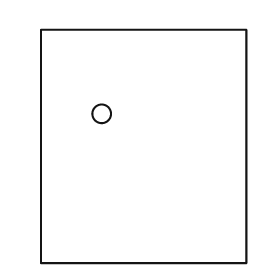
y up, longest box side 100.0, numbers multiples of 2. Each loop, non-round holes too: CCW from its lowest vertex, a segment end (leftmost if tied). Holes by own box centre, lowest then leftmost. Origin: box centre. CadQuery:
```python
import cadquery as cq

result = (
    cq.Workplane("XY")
    .moveTo(-44.0, -50.0)
    .lineTo(44.0, -50.0)
    .lineTo(44.0, 50.0)
    .lineTo(-44.0, 50.0)
    .close()
    .moveTo(-18.0, 14.0)
    .circle(4.0)
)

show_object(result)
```